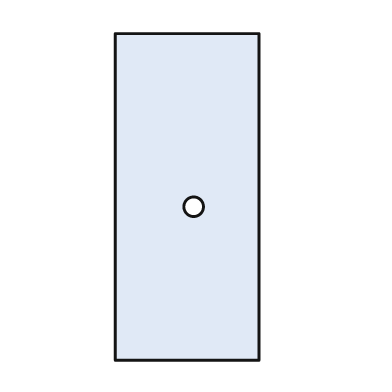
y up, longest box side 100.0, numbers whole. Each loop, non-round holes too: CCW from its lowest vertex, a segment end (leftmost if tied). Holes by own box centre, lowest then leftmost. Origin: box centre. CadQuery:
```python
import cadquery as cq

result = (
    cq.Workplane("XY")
    .moveTo(-22.0, -50.0)
    .lineTo(22.0, -50.0)
    .lineTo(22.0, 50.0)
    .lineTo(-22.0, 50.0)
    .close()
    .moveTo(2.0, -3.0)
    .circle(3.0)
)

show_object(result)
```